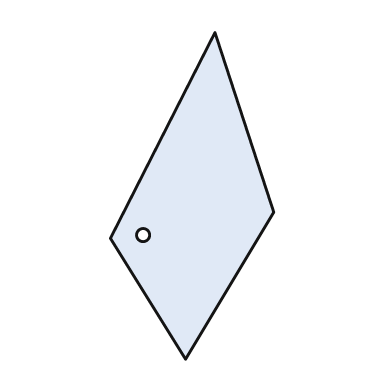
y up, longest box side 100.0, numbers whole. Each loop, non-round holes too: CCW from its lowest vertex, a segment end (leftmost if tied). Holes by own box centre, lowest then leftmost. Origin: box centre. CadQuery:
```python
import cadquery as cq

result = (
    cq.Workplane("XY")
    .moveTo(-2.0, -50.0)
    .lineTo(25.0, -5.0)
    .lineTo(7.0, 50.0)
    .lineTo(-25.0, -13.0)
    .close()
    .moveTo(-15.0, -12.0)
    .circle(2.0)
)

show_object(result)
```